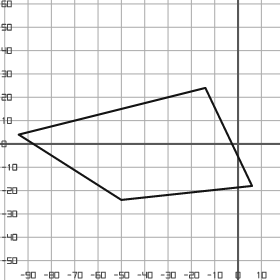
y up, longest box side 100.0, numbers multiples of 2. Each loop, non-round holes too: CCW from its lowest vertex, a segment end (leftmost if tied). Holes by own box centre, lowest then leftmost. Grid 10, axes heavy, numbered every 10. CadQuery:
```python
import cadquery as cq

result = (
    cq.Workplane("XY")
    .moveTo(-50.0, -24.0)
    .lineTo(6.0, -18.0)
    .lineTo(-14.0, 24.0)
    .lineTo(-94.0, 4.0)
    .close()
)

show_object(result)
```